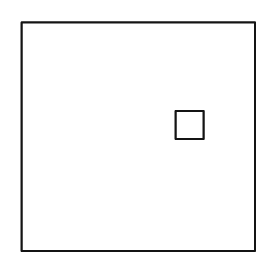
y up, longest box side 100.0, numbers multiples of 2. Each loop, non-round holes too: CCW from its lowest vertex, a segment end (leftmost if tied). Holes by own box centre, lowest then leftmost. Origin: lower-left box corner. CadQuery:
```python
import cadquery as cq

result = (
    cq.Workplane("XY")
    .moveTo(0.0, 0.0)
    .lineTo(100.0, 0.0)
    .lineTo(100.0, 98.0)
    .lineTo(0.0, 98.0)
    .close()
    .moveTo(66.0, 48.0)
    .lineTo(78.0, 48.0)
    .lineTo(78.0, 60.0)
    .lineTo(66.0, 60.0)
    .close()
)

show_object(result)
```